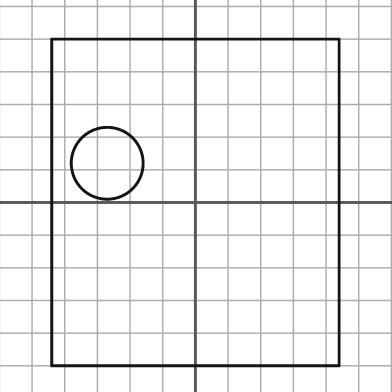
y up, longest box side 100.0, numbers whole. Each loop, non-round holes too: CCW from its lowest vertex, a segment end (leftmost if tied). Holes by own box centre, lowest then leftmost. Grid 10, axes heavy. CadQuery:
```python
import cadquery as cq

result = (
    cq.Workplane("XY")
    .moveTo(-44.0, -50.0)
    .lineTo(44.0, -50.0)
    .lineTo(44.0, 50.0)
    .lineTo(-44.0, 50.0)
    .close()
    .moveTo(-27.0, 12.0)
    .circle(11.0)
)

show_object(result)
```